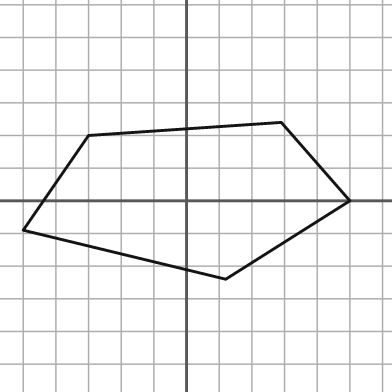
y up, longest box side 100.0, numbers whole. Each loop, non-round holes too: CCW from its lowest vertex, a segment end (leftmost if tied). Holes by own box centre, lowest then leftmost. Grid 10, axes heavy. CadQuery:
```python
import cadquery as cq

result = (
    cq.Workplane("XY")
    .moveTo(12.0, -24.0)
    .lineTo(50.0, 0.0)
    .lineTo(29.0, 24.0)
    .lineTo(-30.0, 20.0)
    .lineTo(-50.0, -9.0)
    .close()
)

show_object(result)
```